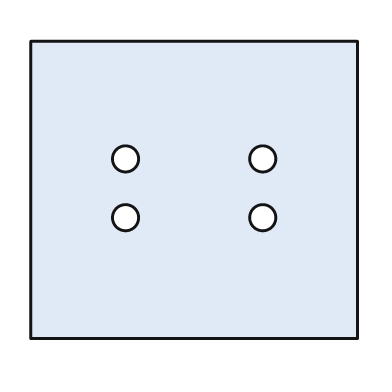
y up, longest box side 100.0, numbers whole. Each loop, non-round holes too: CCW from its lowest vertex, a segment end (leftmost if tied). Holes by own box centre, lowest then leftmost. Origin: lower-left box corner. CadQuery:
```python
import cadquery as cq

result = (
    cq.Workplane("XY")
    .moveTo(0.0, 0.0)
    .lineTo(100.0, 0.0)
    .lineTo(100.0, 91.0)
    .lineTo(0.0, 91.0)
    .close()
    .moveTo(29.0, 37.0)
    .circle(4.0)
    .moveTo(71.0, 37.0)
    .circle(4.0)
    .moveTo(29.0, 55.0)
    .circle(4.0)
    .moveTo(71.0, 55.0)
    .circle(4.0)
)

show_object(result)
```